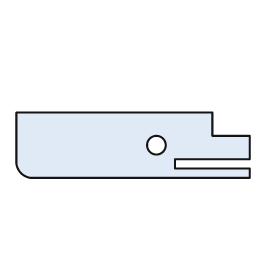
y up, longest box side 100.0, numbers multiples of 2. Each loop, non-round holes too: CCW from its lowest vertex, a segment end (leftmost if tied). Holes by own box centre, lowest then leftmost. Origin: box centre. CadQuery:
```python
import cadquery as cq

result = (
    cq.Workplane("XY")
    .moveTo(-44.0, -14.0)
    .lineTo(50.0, -14.0)
    .lineTo(50.0, -10.0)
    .lineTo(18.0, -10.0)
    .lineTo(18.0, -6.0)
    .lineTo(50.0, -6.0)
    .lineTo(50.0, 4.0)
    .lineTo(34.0, 4.0)
    .lineTo(34.0, 14.0)
    .lineTo(-50.0, 14.0)
    .lineTo(-50.0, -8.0)
    .threePointArc((-48.0, -12.0), (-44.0, -14.0))
    .close()
    .moveTo(10.0, 0.0)
    .circle(4.0)
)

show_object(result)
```